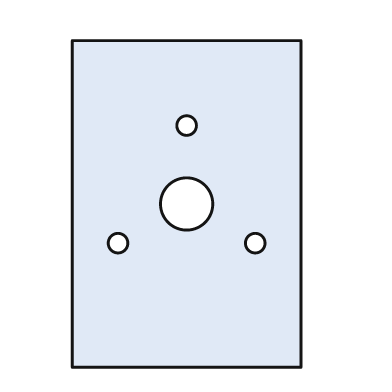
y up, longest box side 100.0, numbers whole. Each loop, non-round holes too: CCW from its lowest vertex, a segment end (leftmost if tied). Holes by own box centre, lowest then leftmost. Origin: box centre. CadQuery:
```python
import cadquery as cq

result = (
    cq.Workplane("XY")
    .moveTo(-35.0, -50.0)
    .lineTo(35.0, -50.0)
    .lineTo(35.0, 50.0)
    .lineTo(-35.0, 50.0)
    .close()
    .moveTo(-21.0, -12.0)
    .circle(3.0)
    .moveTo(21.0, -12.0)
    .circle(3.0)
    .moveTo(0.0, 0.0)
    .circle(8.0)
    .moveTo(0.0, 24.0)
    .circle(3.0)
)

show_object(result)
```